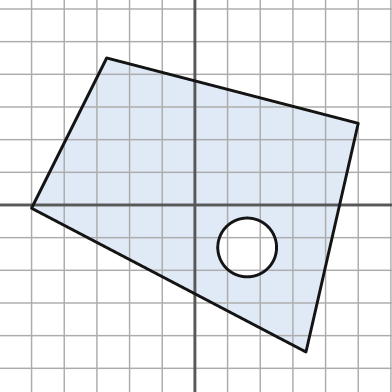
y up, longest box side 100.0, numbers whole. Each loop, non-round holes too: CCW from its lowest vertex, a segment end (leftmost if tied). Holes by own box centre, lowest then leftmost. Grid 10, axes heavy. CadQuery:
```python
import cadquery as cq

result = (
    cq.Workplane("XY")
    .moveTo(34.0, -45.0)
    .lineTo(50.0, 25.0)
    .lineTo(-27.0, 45.0)
    .lineTo(-50.0, -1.0)
    .close()
    .moveTo(16.0, -13.0)
    .circle(9.0)
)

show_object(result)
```